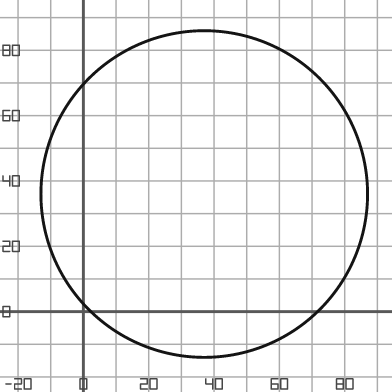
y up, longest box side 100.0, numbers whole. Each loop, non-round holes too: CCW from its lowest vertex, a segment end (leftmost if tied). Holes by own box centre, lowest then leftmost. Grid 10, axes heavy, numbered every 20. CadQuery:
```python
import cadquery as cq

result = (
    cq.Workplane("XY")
    .moveTo(37.0, 36.0)
    .circle(50.0)
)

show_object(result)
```